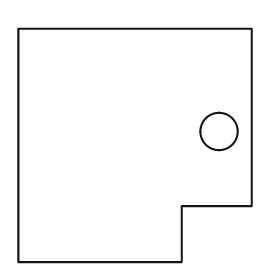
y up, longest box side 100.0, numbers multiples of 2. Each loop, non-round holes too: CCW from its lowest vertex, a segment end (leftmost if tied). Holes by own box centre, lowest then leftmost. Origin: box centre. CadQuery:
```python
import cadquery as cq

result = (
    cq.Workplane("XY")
    .moveTo(-50.0, -50.0)
    .lineTo(20.0, -50.0)
    .lineTo(20.0, -26.0)
    .lineTo(50.0, -26.0)
    .lineTo(50.0, 50.0)
    .lineTo(-50.0, 50.0)
    .close()
    .moveTo(36.0, 6.0)
    .circle(8.0)
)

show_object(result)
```